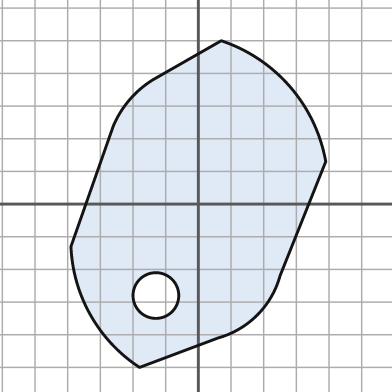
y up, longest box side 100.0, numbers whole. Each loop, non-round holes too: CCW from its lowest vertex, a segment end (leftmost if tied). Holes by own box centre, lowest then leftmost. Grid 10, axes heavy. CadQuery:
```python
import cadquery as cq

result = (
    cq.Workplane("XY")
    .moveTo(-18.0, -50.0)
    .lineTo(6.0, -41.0)
    .threePointArc((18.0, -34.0), (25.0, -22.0))
    .lineTo(39.0, 13.0)
    .threePointArc((28.0, 36.0), (7.0, 50.0))
    .lineTo(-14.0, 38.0)
    .threePointArc((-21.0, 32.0), (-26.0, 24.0))
    .lineTo(-39.0, -13.0)
    .threePointArc((-33.0, -34.0), (-18.0, -50.0))
    .close()
    .moveTo(-13.0, -28.0)
    .circle(7.0)
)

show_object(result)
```